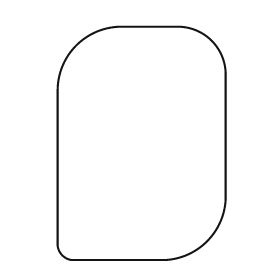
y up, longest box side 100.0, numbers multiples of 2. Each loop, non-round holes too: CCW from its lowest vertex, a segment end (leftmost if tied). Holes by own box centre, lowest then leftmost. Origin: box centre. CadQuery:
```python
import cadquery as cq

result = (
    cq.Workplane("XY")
    .moveTo(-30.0, -50.0)
    .lineTo(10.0, -50.0)
    .threePointArc((28.0, -42.0), (36.0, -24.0))
    .lineTo(36.0, 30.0)
    .threePointArc((30.0, 44.0), (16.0, 50.0))
    .lineTo(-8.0, 50.0)
    .threePointArc((-28.0, 42.0), (-36.0, 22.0))
    .lineTo(-36.0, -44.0)
    .threePointArc((-34.0, -48.0), (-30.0, -50.0))
    .close()
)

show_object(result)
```